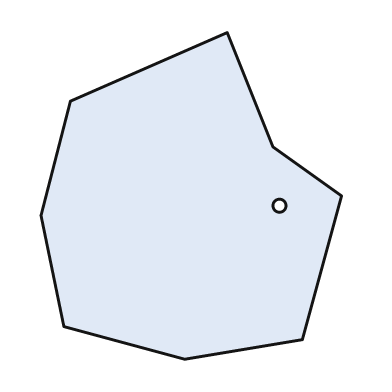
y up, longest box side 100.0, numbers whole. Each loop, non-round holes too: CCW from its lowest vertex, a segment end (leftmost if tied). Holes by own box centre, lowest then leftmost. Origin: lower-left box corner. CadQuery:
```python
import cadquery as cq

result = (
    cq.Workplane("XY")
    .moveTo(44.0, 0.0)
    .lineTo(80.0, 6.0)
    .lineTo(92.0, 50.0)
    .lineTo(71.0, 65.0)
    .lineTo(57.0, 100.0)
    .lineTo(9.0, 79.0)
    .lineTo(0.0, 44.0)
    .lineTo(7.0, 10.0)
    .close()
    .moveTo(73.0, 47.0)
    .circle(2.0)
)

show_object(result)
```